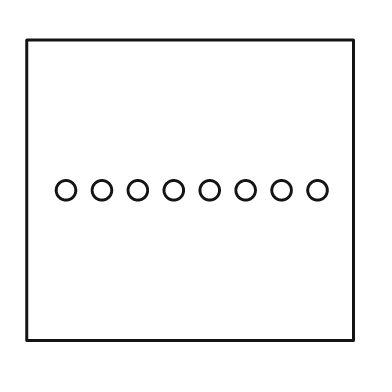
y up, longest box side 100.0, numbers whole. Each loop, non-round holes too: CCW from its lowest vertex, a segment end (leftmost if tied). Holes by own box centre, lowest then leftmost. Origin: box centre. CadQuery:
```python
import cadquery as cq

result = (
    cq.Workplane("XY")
    .moveTo(-50.0, -46.0)
    .lineTo(50.0, -46.0)
    .lineTo(50.0, 46.0)
    .lineTo(-50.0, 46.0)
    .close()
    .moveTo(-38.0, 0.0)
    .circle(3.0)
    .moveTo(-27.0, 0.0)
    .circle(3.0)
    .moveTo(-16.0, 0.0)
    .circle(3.0)
    .moveTo(-5.0, 0.0)
    .circle(3.0)
    .moveTo(6.0, 0.0)
    .circle(3.0)
    .moveTo(17.0, 0.0)
    .circle(3.0)
    .moveTo(28.0, 0.0)
    .circle(3.0)
    .moveTo(39.0, 0.0)
    .circle(3.0)
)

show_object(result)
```